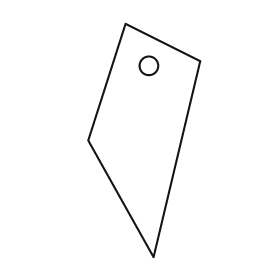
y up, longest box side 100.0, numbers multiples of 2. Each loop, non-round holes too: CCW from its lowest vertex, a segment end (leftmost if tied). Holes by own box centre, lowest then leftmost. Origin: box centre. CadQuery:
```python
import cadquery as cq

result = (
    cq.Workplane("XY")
    .moveTo(4.0, -50.0)
    .lineTo(24.0, 34.0)
    .lineTo(-8.0, 50.0)
    .lineTo(-24.0, 0.0)
    .close()
    .moveTo(2.0, 32.0)
    .circle(4.0)
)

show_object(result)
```